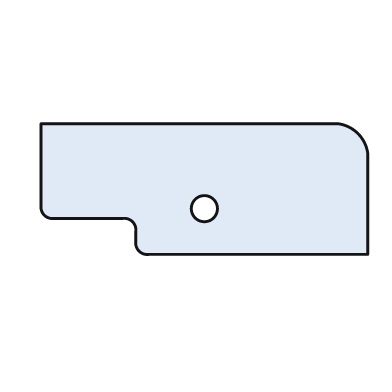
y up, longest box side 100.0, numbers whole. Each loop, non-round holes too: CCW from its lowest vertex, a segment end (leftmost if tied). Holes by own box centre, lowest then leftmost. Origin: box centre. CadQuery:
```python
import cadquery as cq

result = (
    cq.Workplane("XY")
    .moveTo(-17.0, -20.0)
    .lineTo(50.0, -20.0)
    .lineTo(50.0, 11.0)
    .threePointArc((47.0, 17.0), (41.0, 20.0))
    .lineTo(-50.0, 20.0)
    .lineTo(-50.0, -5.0)
    .threePointArc((-49.0, -8.0), (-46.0, -9.0))
    .lineTo(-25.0, -9.0)
    .threePointArc((-22.0, -10.0), (-21.0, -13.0))
    .lineTo(-21.0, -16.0)
    .threePointArc((-20.0, -19.0), (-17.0, -20.0))
    .close()
    .moveTo(0.0, -6.0)
    .circle(4.0)
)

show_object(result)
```